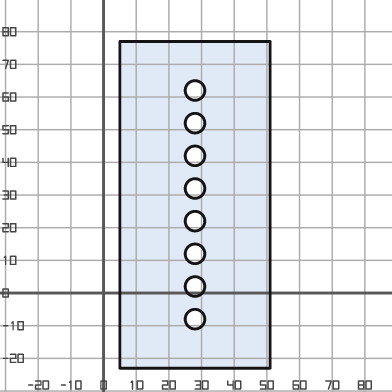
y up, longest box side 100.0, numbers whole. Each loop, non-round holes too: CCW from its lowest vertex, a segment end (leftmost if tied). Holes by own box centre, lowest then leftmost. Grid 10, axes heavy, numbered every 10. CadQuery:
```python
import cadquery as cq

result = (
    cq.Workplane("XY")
    .moveTo(5.0, -23.0)
    .lineTo(51.0, -23.0)
    .lineTo(51.0, 77.0)
    .lineTo(5.0, 77.0)
    .close()
    .moveTo(28.0, -8.0)
    .circle(3.0)
    .moveTo(28.0, 2.0)
    .circle(3.0)
    .moveTo(28.0, 12.0)
    .circle(3.0)
    .moveTo(28.0, 22.0)
    .circle(3.0)
    .moveTo(28.0, 32.0)
    .circle(3.0)
    .moveTo(28.0, 42.0)
    .circle(3.0)
    .moveTo(28.0, 52.0)
    .circle(3.0)
    .moveTo(28.0, 62.0)
    .circle(3.0)
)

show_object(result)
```